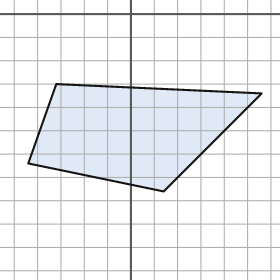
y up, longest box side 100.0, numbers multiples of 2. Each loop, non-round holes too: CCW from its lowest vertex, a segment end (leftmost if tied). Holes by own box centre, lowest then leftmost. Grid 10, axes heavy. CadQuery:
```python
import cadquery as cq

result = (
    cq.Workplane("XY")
    .moveTo(14.0, -76.0)
    .lineTo(56.0, -34.0)
    .lineTo(-32.0, -30.0)
    .lineTo(-44.0, -64.0)
    .close()
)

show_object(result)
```